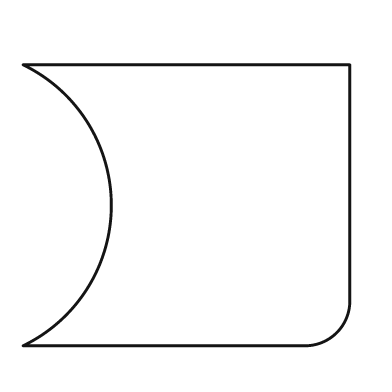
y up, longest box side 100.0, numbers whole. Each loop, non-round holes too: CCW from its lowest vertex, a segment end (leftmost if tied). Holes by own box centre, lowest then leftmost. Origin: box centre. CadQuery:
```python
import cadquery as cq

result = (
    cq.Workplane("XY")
    .moveTo(-50.0, -43.0)
    .lineTo(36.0, -43.0)
    .threePointArc((46.0, -39.0), (50.0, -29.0))
    .lineTo(50.0, 43.0)
    .lineTo(-50.0, 43.0)
    .threePointArc((-23.0, 0.0), (-50.0, -43.0))
    .close()
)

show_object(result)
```